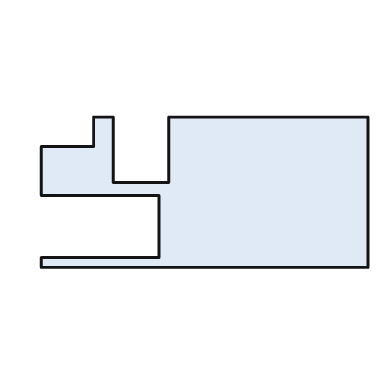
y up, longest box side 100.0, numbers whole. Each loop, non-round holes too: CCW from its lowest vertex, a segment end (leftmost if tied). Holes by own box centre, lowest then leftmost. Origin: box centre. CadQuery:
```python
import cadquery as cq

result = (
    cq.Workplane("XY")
    .moveTo(-50.0, -23.0)
    .lineTo(50.0, -23.0)
    .lineTo(50.0, 23.0)
    .lineTo(-11.0, 23.0)
    .lineTo(-11.0, 3.0)
    .lineTo(-28.0, 3.0)
    .lineTo(-28.0, 23.0)
    .lineTo(-34.0, 23.0)
    .lineTo(-34.0, 14.0)
    .lineTo(-50.0, 14.0)
    .lineTo(-50.0, -1.0)
    .lineTo(-14.0, -1.0)
    .lineTo(-14.0, -20.0)
    .lineTo(-50.0, -20.0)
    .close()
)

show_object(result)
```